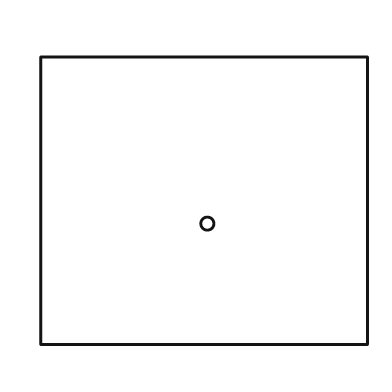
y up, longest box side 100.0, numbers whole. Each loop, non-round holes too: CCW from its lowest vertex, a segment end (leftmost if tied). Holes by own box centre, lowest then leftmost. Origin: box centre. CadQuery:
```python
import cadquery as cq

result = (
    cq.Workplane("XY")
    .moveTo(-50.0, -44.0)
    .lineTo(50.0, -44.0)
    .lineTo(50.0, 44.0)
    .lineTo(-50.0, 44.0)
    .close()
    .moveTo(1.0, -7.0)
    .circle(2.0)
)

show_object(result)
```